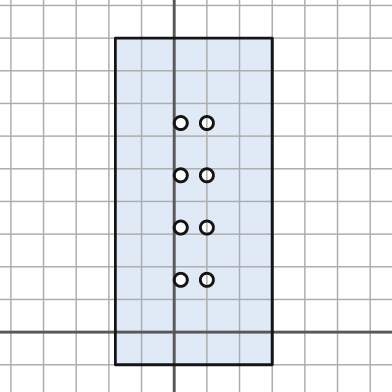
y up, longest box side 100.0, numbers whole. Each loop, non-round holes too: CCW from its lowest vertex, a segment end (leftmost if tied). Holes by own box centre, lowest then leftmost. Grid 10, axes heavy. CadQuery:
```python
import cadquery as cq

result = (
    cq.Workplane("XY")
    .moveTo(-18.0, -10.0)
    .lineTo(30.0, -10.0)
    .lineTo(30.0, 90.0)
    .lineTo(-18.0, 90.0)
    .close()
    .moveTo(2.0, 16.0)
    .circle(2.0)
    .moveTo(10.0, 16.0)
    .circle(2.0)
    .moveTo(2.0, 32.0)
    .circle(2.0)
    .moveTo(10.0, 32.0)
    .circle(2.0)
    .moveTo(2.0, 48.0)
    .circle(2.0)
    .moveTo(10.0, 48.0)
    .circle(2.0)
    .moveTo(2.0, 64.0)
    .circle(2.0)
    .moveTo(10.0, 64.0)
    .circle(2.0)
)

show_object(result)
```